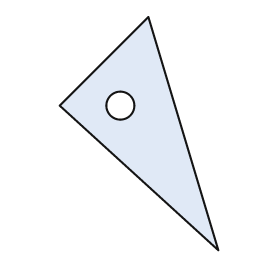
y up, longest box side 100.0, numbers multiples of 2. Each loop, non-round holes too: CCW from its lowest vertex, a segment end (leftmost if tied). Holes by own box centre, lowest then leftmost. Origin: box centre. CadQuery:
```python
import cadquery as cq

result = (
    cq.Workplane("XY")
    .moveTo(34.0, -50.0)
    .lineTo(4.0, 50.0)
    .lineTo(-34.0, 12.0)
    .close()
    .moveTo(-8.0, 12.0)
    .circle(6.0)
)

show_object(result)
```